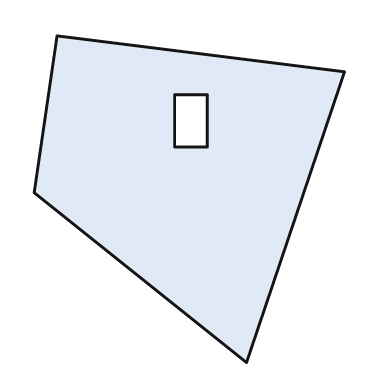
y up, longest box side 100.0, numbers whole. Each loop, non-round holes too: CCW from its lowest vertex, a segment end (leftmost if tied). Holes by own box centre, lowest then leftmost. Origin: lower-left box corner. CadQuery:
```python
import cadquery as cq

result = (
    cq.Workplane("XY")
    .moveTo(65.0, 0.0)
    .lineTo(95.0, 89.0)
    .lineTo(7.0, 100.0)
    .lineTo(0.0, 52.0)
    .close()
    .moveTo(43.0, 66.0)
    .lineTo(53.0, 66.0)
    .lineTo(53.0, 82.0)
    .lineTo(43.0, 82.0)
    .close()
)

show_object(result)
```